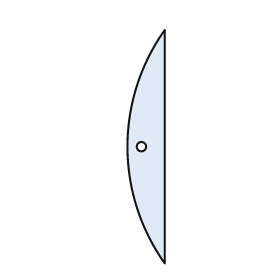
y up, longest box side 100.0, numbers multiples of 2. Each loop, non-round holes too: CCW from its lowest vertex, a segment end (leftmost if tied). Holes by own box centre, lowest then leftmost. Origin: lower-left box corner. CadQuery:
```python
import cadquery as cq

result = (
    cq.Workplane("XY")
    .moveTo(16.0, 0.0)
    .lineTo(16.0, 100.0)
    .threePointArc((0.0, 50.0), (16.0, 0.0))
    .close()
    .moveTo(6.0, 50.0)
    .circle(2.0)
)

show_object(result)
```